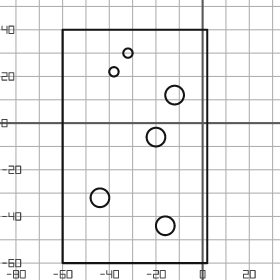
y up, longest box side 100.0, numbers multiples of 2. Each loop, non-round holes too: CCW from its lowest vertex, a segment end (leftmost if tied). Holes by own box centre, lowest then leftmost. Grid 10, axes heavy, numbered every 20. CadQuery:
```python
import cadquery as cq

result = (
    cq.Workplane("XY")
    .moveTo(-60.0, -60.0)
    .lineTo(2.0, -60.0)
    .lineTo(2.0, 40.0)
    .lineTo(-60.0, 40.0)
    .close()
    .moveTo(-16.0, -44.0)
    .circle(4.0)
    .moveTo(-44.0, -32.0)
    .circle(4.0)
    .moveTo(-20.0, -6.0)
    .circle(4.0)
    .moveTo(-12.0, 12.0)
    .circle(4.0)
    .moveTo(-38.0, 22.0)
    .circle(2.0)
    .moveTo(-32.0, 30.0)
    .circle(2.0)
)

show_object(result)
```